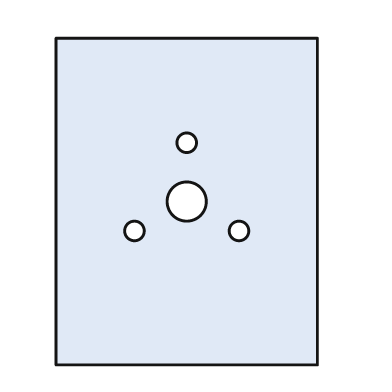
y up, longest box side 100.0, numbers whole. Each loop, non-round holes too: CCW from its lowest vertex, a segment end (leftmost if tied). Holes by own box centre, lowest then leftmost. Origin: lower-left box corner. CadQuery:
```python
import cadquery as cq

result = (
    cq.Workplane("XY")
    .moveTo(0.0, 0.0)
    .lineTo(80.0, 0.0)
    .lineTo(80.0, 100.0)
    .lineTo(0.0, 100.0)
    .close()
    .moveTo(24.0, 41.0)
    .circle(3.0)
    .moveTo(56.0, 41.0)
    .circle(3.0)
    .moveTo(40.0, 50.0)
    .circle(6.0)
    .moveTo(40.0, 68.0)
    .circle(3.0)
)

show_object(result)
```